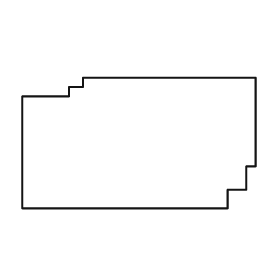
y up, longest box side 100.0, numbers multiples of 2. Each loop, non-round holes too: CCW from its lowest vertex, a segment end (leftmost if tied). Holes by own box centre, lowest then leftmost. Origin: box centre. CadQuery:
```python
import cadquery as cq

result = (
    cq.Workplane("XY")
    .moveTo(-50.0, -28.0)
    .lineTo(38.0, -28.0)
    .lineTo(38.0, -20.0)
    .lineTo(46.0, -20.0)
    .lineTo(46.0, -10.0)
    .lineTo(50.0, -10.0)
    .lineTo(50.0, 28.0)
    .lineTo(-24.0, 28.0)
    .lineTo(-24.0, 24.0)
    .lineTo(-30.0, 24.0)
    .lineTo(-30.0, 20.0)
    .lineTo(-50.0, 20.0)
    .close()
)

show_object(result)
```